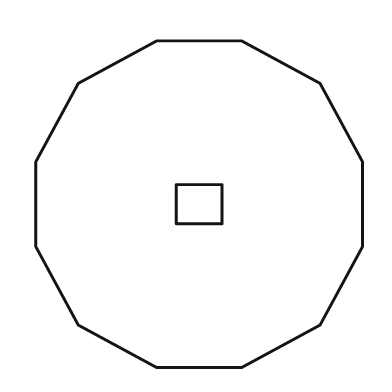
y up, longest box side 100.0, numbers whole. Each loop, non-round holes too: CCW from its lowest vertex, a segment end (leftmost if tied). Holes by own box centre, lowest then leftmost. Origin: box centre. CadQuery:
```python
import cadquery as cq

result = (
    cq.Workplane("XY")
    .moveTo(-13.0, -50.0)
    .lineTo(13.0, -50.0)
    .lineTo(37.0, -37.0)
    .lineTo(50.0, -13.0)
    .lineTo(50.0, 13.0)
    .lineTo(37.0, 37.0)
    .lineTo(13.0, 50.0)
    .lineTo(-13.0, 50.0)
    .lineTo(-37.0, 37.0)
    .lineTo(-50.0, 13.0)
    .lineTo(-50.0, -13.0)
    .lineTo(-37.0, -37.0)
    .close()
    .moveTo(-7.0, -6.0)
    .lineTo(7.0, -6.0)
    .lineTo(7.0, 6.0)
    .lineTo(-7.0, 6.0)
    .close()
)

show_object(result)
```